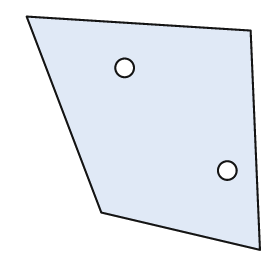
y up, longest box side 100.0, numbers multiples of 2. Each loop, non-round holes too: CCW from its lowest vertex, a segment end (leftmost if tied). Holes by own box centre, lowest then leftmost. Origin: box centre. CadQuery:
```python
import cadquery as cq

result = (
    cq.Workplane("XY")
    .moveTo(50.0, -50.0)
    .lineTo(46.0, 44.0)
    .lineTo(-50.0, 50.0)
    .lineTo(-18.0, -34.0)
    .close()
    .moveTo(36.0, -16.0)
    .circle(4.0)
    .moveTo(-8.0, 28.0)
    .circle(4.0)
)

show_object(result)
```